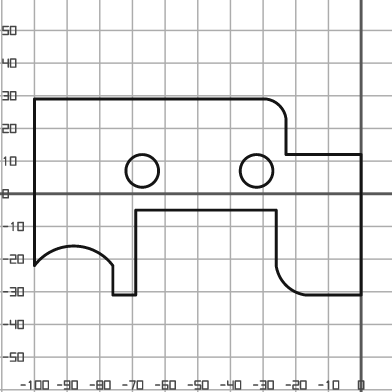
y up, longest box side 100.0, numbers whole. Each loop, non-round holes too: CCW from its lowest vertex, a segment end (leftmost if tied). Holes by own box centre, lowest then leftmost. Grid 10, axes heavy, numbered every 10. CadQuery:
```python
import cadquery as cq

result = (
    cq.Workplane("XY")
    .moveTo(-76.0, -31.0)
    .lineTo(-69.0, -31.0)
    .lineTo(-69.0, -5.0)
    .lineTo(-26.0, -5.0)
    .lineTo(-26.0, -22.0)
    .threePointArc((-23.0, -28.0), (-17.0, -31.0))
    .lineTo(0.0, -31.0)
    .lineTo(0.0, 12.0)
    .lineTo(-23.0, 12.0)
    .lineTo(-23.0, 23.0)
    .threePointArc((-25.0, 27.0), (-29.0, 29.0))
    .lineTo(-100.0, 29.0)
    .lineTo(-100.0, -22.0)
    .threePointArc((-88.0, -16.0), (-76.0, -22.0))
    .close()
    .moveTo(-67.0, 7.0)
    .circle(5.0)
    .moveTo(-32.0, 7.0)
    .circle(5.0)
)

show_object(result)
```